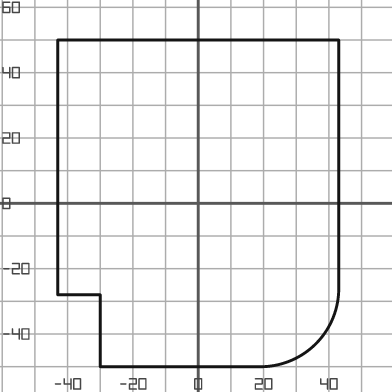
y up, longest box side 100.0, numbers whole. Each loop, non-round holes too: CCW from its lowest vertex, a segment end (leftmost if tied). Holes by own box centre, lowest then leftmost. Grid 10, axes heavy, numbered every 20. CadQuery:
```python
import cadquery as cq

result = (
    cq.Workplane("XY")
    .moveTo(-30.0, -50.0)
    .lineTo(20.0, -50.0)
    .threePointArc((36.0, -43.0), (43.0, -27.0))
    .lineTo(43.0, 50.0)
    .lineTo(-43.0, 50.0)
    .lineTo(-43.0, -28.0)
    .lineTo(-30.0, -28.0)
    .close()
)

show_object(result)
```